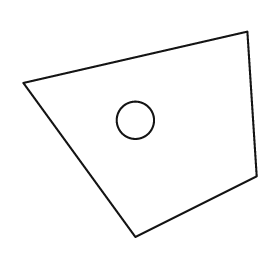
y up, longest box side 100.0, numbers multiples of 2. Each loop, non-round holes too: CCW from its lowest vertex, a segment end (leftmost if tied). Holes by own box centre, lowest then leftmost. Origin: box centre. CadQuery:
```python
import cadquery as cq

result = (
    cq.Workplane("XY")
    .moveTo(-2.0, -44.0)
    .lineTo(50.0, -18.0)
    .lineTo(46.0, 44.0)
    .lineTo(-50.0, 22.0)
    .close()
    .moveTo(-2.0, 6.0)
    .circle(8.0)
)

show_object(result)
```